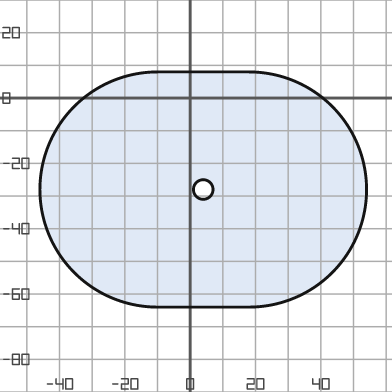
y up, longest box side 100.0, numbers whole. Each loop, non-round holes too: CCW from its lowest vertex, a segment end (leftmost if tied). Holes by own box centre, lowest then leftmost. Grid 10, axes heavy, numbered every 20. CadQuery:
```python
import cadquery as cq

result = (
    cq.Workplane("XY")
    .moveTo(-10.0, -64.0)
    .lineTo(18.0, -64.0)
    .threePointArc((54.0, -28.0), (18.0, 8.0))
    .lineTo(-10.0, 8.0)
    .threePointArc((-46.0, -28.0), (-10.0, -64.0))
    .close()
    .moveTo(4.0, -28.0)
    .circle(3.0)
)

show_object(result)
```